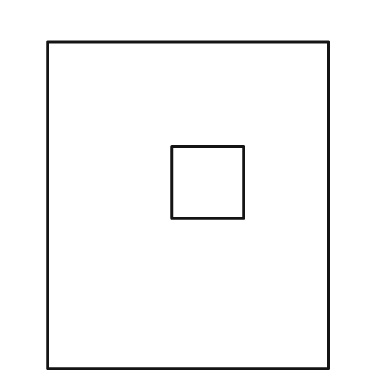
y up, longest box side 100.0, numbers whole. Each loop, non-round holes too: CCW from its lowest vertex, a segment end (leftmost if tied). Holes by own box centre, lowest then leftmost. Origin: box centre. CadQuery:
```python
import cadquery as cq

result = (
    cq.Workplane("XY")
    .moveTo(-43.0, -50.0)
    .lineTo(43.0, -50.0)
    .lineTo(43.0, 50.0)
    .lineTo(-43.0, 50.0)
    .close()
    .moveTo(-5.0, -4.0)
    .lineTo(17.0, -4.0)
    .lineTo(17.0, 18.0)
    .lineTo(-5.0, 18.0)
    .close()
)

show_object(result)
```